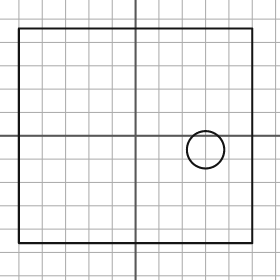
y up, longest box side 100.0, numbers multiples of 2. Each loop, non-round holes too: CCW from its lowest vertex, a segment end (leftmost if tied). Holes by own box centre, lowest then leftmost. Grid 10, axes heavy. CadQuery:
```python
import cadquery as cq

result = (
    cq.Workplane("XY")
    .moveTo(-50.0, -46.0)
    .lineTo(50.0, -46.0)
    .lineTo(50.0, 46.0)
    .lineTo(-50.0, 46.0)
    .close()
    .moveTo(30.0, -6.0)
    .circle(8.0)
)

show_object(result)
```